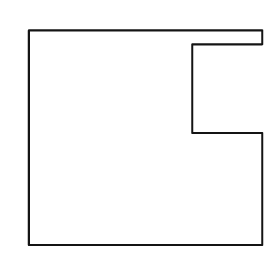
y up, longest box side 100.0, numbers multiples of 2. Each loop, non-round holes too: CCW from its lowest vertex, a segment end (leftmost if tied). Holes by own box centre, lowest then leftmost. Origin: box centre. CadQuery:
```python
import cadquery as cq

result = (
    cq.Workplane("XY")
    .moveTo(-50.0, -46.0)
    .lineTo(50.0, -46.0)
    .lineTo(50.0, 2.0)
    .lineTo(20.0, 2.0)
    .lineTo(20.0, 40.0)
    .lineTo(50.0, 40.0)
    .lineTo(50.0, 46.0)
    .lineTo(-50.0, 46.0)
    .close()
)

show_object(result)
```